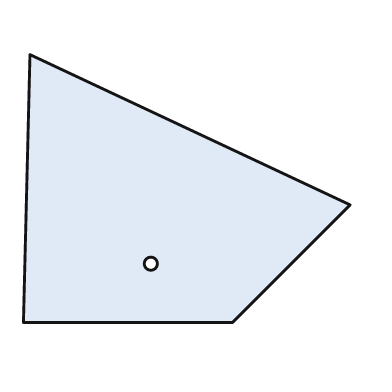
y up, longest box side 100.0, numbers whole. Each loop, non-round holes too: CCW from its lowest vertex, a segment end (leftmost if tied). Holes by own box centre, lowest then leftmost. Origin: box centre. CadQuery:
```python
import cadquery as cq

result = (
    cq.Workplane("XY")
    .moveTo(-50.0, -41.0)
    .lineTo(14.0, -41.0)
    .lineTo(50.0, -5.0)
    .lineTo(-48.0, 41.0)
    .close()
    .moveTo(-11.0, -23.0)
    .circle(2.0)
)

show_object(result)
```